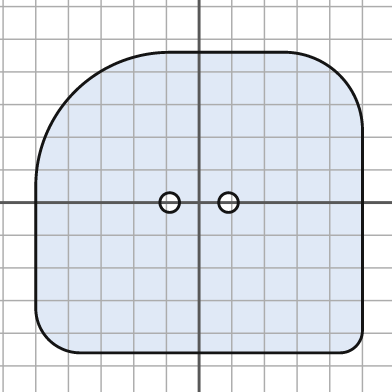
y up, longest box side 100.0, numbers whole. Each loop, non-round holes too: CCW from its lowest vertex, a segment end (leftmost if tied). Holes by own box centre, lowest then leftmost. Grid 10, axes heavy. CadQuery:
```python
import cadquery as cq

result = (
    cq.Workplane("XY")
    .moveTo(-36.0, -46.0)
    .lineTo(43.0, -46.0)
    .threePointArc((48.0, -44.0), (50.0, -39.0))
    .lineTo(50.0, 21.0)
    .threePointArc((43.0, 39.0), (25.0, 46.0))
    .lineTo(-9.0, 46.0)
    .threePointArc((-38.0, 34.0), (-50.0, 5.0))
    .lineTo(-50.0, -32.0)
    .threePointArc((-46.0, -42.0), (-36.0, -46.0))
    .close()
    .moveTo(-9.0, 0.0)
    .circle(3.0)
    .moveTo(9.0, 0.0)
    .circle(3.0)
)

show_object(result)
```